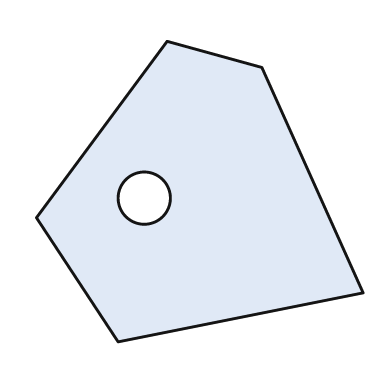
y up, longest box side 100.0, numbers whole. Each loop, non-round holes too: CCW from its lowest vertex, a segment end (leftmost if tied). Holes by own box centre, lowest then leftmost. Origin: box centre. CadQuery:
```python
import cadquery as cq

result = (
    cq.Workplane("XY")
    .moveTo(-25.0, -46.0)
    .lineTo(50.0, -31.0)
    .lineTo(19.0, 38.0)
    .lineTo(-10.0, 46.0)
    .lineTo(-50.0, -8.0)
    .close()
    .moveTo(-17.0, -2.0)
    .circle(8.0)
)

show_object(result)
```